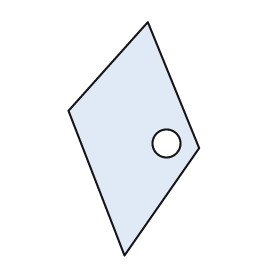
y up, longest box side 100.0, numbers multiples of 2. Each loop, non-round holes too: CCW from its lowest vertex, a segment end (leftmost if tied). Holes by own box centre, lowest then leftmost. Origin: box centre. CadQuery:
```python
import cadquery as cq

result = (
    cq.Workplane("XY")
    .moveTo(-4.0, -50.0)
    .lineTo(28.0, -4.0)
    .lineTo(6.0, 50.0)
    .lineTo(-28.0, 12.0)
    .close()
    .moveTo(14.0, -2.0)
    .circle(6.0)
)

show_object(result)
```